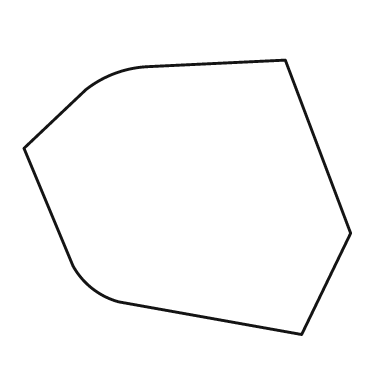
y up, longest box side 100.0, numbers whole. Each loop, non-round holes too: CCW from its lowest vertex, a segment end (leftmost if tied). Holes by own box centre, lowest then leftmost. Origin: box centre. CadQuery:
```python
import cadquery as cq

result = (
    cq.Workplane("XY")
    .moveTo(35.0, -42.0)
    .lineTo(50.0, -11.0)
    .lineTo(30.0, 42.0)
    .lineTo(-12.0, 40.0)
    .threePointArc((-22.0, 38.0), (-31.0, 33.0))
    .lineTo(-50.0, 15.0)
    .lineTo(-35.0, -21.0)
    .threePointArc((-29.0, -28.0), (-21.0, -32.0))
    .close()
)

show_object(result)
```